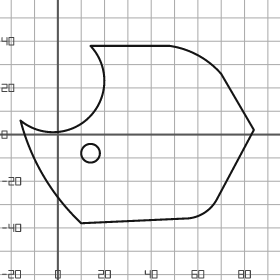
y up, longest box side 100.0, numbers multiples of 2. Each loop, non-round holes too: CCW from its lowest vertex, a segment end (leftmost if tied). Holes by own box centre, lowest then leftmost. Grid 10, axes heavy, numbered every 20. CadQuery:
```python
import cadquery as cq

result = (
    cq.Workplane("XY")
    .moveTo(10.0, -38.0)
    .lineTo(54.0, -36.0)
    .threePointArc((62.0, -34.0), (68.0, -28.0))
    .lineTo(84.0, 2.0)
    .lineTo(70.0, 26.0)
    .threePointArc((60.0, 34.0), (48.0, 38.0))
    .lineTo(14.0, 38.0)
    .threePointArc((14.0, 8.0), (-16.0, 6.0))
    .threePointArc((-6.0, -18.0), (10.0, -38.0))
    .close()
    .moveTo(14.0, -8.0)
    .circle(4.0)
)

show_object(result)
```